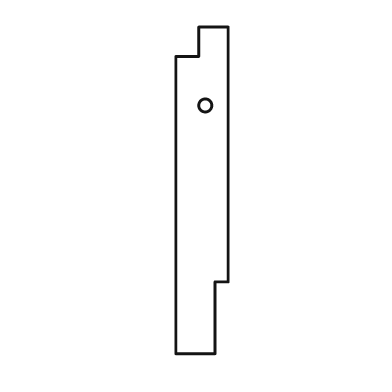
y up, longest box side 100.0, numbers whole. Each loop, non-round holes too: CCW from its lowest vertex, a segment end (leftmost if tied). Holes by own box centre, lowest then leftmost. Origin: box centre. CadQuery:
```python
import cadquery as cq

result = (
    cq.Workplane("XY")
    .moveTo(-8.0, -50.0)
    .lineTo(4.0, -50.0)
    .lineTo(4.0, -28.0)
    .lineTo(8.0, -28.0)
    .lineTo(8.0, 50.0)
    .lineTo(-1.0, 50.0)
    .lineTo(-1.0, 41.0)
    .lineTo(-8.0, 41.0)
    .close()
    .moveTo(1.0, 26.0)
    .circle(2.0)
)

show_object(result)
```